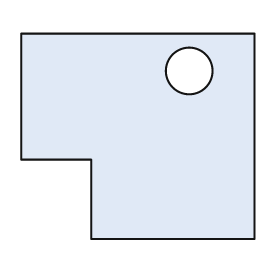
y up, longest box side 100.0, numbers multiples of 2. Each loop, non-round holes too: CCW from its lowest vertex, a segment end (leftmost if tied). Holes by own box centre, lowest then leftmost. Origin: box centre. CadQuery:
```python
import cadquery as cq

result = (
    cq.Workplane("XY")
    .moveTo(-20.0, -44.0)
    .lineTo(50.0, -44.0)
    .lineTo(50.0, 44.0)
    .lineTo(-50.0, 44.0)
    .lineTo(-50.0, -10.0)
    .lineTo(-20.0, -10.0)
    .close()
    .moveTo(22.0, 28.0)
    .circle(10.0)
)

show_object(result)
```